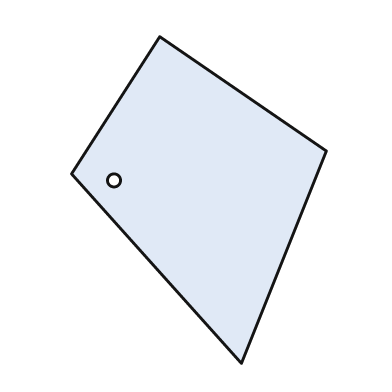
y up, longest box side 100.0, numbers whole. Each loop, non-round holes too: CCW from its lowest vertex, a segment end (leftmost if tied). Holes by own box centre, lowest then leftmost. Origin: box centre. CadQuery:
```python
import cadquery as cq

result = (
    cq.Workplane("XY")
    .moveTo(13.0, -50.0)
    .lineTo(39.0, 15.0)
    .lineTo(-12.0, 50.0)
    .lineTo(-39.0, 8.0)
    .close()
    .moveTo(-26.0, 6.0)
    .circle(2.0)
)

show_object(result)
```